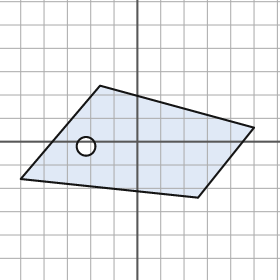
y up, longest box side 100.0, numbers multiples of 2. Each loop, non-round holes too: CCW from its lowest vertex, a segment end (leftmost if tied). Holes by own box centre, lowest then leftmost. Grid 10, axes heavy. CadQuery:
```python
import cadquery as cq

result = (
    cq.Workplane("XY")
    .moveTo(26.0, -24.0)
    .lineTo(50.0, 6.0)
    .lineTo(-16.0, 24.0)
    .lineTo(-50.0, -16.0)
    .close()
    .moveTo(-22.0, -2.0)
    .circle(4.0)
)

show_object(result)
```